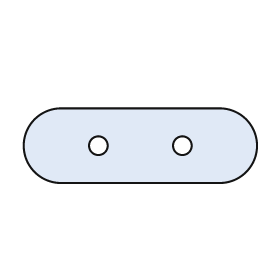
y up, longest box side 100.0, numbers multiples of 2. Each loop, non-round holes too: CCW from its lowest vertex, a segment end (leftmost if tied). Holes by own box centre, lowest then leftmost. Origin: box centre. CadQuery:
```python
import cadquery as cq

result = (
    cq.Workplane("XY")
    .moveTo(-34.0, -16.0)
    .lineTo(34.0, -16.0)
    .threePointArc((50.0, 0.0), (34.0, 16.0))
    .lineTo(-34.0, 16.0)
    .threePointArc((-50.0, 0.0), (-34.0, -16.0))
    .close()
    .moveTo(-18.0, 0.0)
    .circle(4.0)
    .moveTo(18.0, 0.0)
    .circle(4.0)
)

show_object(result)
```